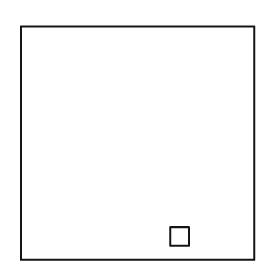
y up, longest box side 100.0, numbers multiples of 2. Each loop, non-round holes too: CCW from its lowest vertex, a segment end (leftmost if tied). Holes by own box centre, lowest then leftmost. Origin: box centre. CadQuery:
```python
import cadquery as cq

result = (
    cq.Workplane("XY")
    .moveTo(-50.0, -50.0)
    .lineTo(50.0, -50.0)
    .lineTo(50.0, 50.0)
    .lineTo(-50.0, 50.0)
    .close()
    .moveTo(14.0, -44.0)
    .lineTo(22.0, -44.0)
    .lineTo(22.0, -36.0)
    .lineTo(14.0, -36.0)
    .close()
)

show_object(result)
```